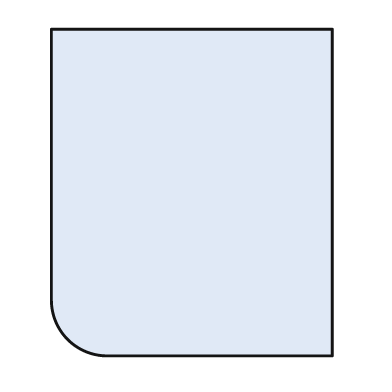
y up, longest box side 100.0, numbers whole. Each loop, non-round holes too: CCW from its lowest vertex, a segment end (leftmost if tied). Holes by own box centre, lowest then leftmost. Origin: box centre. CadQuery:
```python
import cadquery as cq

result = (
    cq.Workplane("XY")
    .moveTo(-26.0, -50.0)
    .lineTo(43.0, -50.0)
    .lineTo(43.0, 50.0)
    .lineTo(-43.0, 50.0)
    .lineTo(-43.0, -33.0)
    .threePointArc((-38.0, -45.0), (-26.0, -50.0))
    .close()
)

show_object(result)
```